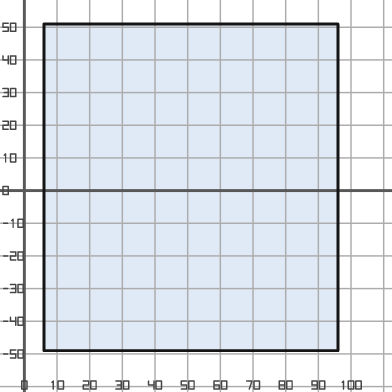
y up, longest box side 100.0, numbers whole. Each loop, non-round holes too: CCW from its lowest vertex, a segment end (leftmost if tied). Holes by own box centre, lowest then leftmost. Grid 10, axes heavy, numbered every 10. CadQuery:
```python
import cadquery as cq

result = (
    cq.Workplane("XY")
    .moveTo(6.0, -49.0)
    .lineTo(96.0, -49.0)
    .lineTo(96.0, 51.0)
    .lineTo(6.0, 51.0)
    .close()
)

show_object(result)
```